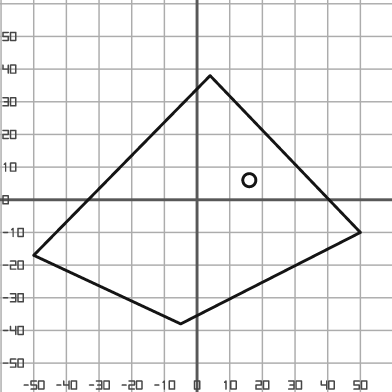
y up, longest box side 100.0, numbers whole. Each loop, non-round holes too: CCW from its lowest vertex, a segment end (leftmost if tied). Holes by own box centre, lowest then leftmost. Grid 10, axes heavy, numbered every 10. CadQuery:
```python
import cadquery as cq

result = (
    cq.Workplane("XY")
    .moveTo(-5.0, -38.0)
    .lineTo(50.0, -10.0)
    .lineTo(4.0, 38.0)
    .lineTo(-50.0, -17.0)
    .close()
    .moveTo(16.0, 6.0)
    .circle(2.0)
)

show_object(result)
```